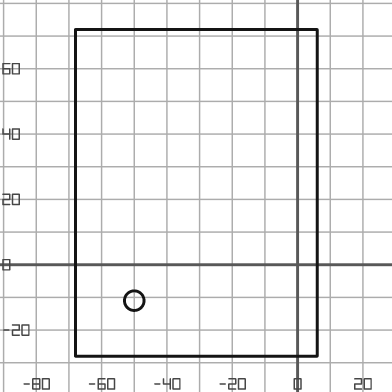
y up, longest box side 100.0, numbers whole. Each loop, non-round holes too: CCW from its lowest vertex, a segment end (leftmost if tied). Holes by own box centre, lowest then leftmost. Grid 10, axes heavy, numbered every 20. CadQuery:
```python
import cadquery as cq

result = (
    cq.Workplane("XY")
    .moveTo(-68.0, -28.0)
    .lineTo(6.0, -28.0)
    .lineTo(6.0, 72.0)
    .lineTo(-68.0, 72.0)
    .close()
    .moveTo(-50.0, -11.0)
    .circle(3.0)
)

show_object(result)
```